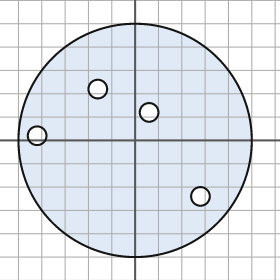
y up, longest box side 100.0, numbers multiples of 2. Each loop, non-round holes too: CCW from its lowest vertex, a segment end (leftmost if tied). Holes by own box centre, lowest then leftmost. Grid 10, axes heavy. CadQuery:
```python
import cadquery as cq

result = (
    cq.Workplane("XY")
    .moveTo(0.0, 0.0)
    .circle(50.0)
    .moveTo(28.0, -24.0)
    .circle(4.0)
    .moveTo(-42.0, 2.0)
    .circle(4.0)
    .moveTo(6.0, 12.0)
    .circle(4.0)
    .moveTo(-16.0, 22.0)
    .circle(4.0)
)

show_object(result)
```